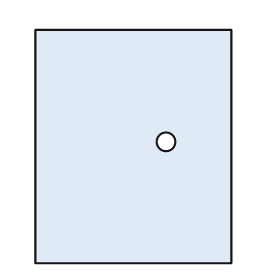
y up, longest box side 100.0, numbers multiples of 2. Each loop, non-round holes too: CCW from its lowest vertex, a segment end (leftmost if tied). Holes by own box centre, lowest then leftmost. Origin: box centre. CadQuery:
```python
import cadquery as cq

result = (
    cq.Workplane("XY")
    .moveTo(-42.0, -50.0)
    .lineTo(42.0, -50.0)
    .lineTo(42.0, 50.0)
    .lineTo(-42.0, 50.0)
    .close()
    .moveTo(14.0, 2.0)
    .circle(4.0)
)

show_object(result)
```